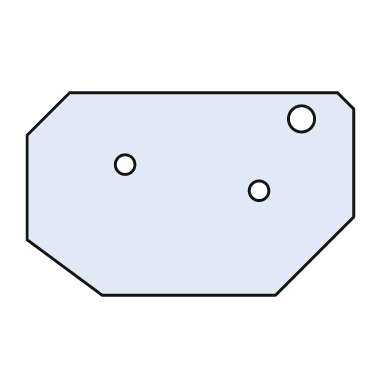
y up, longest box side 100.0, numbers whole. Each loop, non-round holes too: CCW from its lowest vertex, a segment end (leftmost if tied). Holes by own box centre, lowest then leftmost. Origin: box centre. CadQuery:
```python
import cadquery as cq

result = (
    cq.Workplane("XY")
    .moveTo(-27.0, -31.0)
    .lineTo(26.0, -31.0)
    .lineTo(50.0, -7.0)
    .lineTo(50.0, 26.0)
    .lineTo(45.0, 31.0)
    .lineTo(-37.0, 31.0)
    .lineTo(-50.0, 18.0)
    .lineTo(-50.0, -14.0)
    .close()
    .moveTo(21.0, 1.0)
    .circle(3.0)
    .moveTo(-20.0, 9.0)
    .circle(3.0)
    .moveTo(34.0, 23.0)
    .circle(4.0)
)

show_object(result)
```